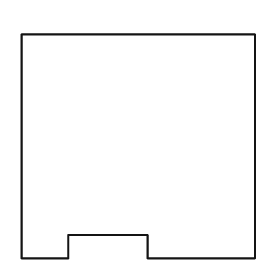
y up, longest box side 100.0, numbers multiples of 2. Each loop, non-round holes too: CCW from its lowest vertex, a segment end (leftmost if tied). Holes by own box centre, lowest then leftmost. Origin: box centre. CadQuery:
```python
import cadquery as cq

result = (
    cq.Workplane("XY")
    .moveTo(-50.0, -48.0)
    .lineTo(-30.0, -48.0)
    .lineTo(-30.0, -38.0)
    .lineTo(4.0, -38.0)
    .lineTo(4.0, -48.0)
    .lineTo(50.0, -48.0)
    .lineTo(50.0, 48.0)
    .lineTo(-50.0, 48.0)
    .close()
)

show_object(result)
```